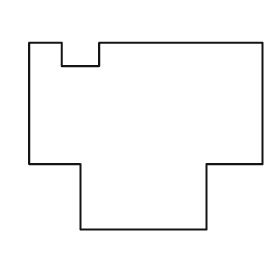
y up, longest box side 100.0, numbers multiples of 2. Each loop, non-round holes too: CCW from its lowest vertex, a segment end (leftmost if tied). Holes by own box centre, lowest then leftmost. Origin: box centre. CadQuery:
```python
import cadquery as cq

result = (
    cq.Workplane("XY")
    .moveTo(-28.0, -40.0)
    .lineTo(26.0, -40.0)
    .lineTo(26.0, -12.0)
    .lineTo(50.0, -12.0)
    .lineTo(50.0, 40.0)
    .lineTo(-20.0, 40.0)
    .lineTo(-20.0, 30.0)
    .lineTo(-36.0, 30.0)
    .lineTo(-36.0, 40.0)
    .lineTo(-50.0, 40.0)
    .lineTo(-50.0, -12.0)
    .lineTo(-28.0, -12.0)
    .close()
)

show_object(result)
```